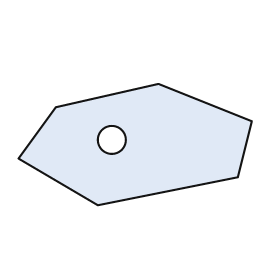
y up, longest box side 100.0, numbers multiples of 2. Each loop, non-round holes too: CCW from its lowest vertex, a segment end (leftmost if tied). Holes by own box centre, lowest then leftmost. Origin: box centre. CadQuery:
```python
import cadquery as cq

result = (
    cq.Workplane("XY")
    .moveTo(-16.0, -26.0)
    .lineTo(44.0, -14.0)
    .lineTo(50.0, 10.0)
    .lineTo(10.0, 26.0)
    .lineTo(-34.0, 16.0)
    .lineTo(-50.0, -6.0)
    .close()
    .moveTo(-10.0, 2.0)
    .circle(6.0)
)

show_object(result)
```